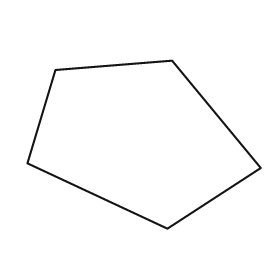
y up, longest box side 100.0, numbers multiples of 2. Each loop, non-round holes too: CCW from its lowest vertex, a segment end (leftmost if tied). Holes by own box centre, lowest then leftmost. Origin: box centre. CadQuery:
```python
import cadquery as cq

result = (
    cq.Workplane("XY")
    .moveTo(10.0, -36.0)
    .lineTo(50.0, -10.0)
    .lineTo(12.0, 36.0)
    .lineTo(-38.0, 32.0)
    .lineTo(-50.0, -8.0)
    .close()
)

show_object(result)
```